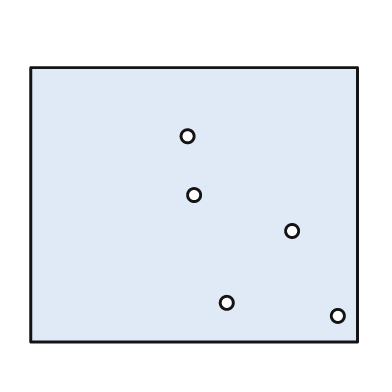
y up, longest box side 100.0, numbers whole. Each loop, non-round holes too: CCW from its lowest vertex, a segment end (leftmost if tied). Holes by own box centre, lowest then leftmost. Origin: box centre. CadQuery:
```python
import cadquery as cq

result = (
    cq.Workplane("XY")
    .moveTo(-50.0, -42.0)
    .lineTo(50.0, -42.0)
    .lineTo(50.0, 42.0)
    .lineTo(-50.0, 42.0)
    .close()
    .moveTo(44.0, -34.0)
    .circle(2.0)
    .moveTo(10.0, -30.0)
    .circle(2.0)
    .moveTo(30.0, -8.0)
    .circle(2.0)
    .moveTo(0.0, 3.0)
    .circle(2.0)
    .moveTo(-2.0, 21.0)
    .circle(2.0)
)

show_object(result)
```